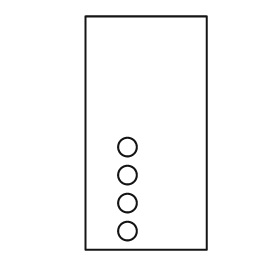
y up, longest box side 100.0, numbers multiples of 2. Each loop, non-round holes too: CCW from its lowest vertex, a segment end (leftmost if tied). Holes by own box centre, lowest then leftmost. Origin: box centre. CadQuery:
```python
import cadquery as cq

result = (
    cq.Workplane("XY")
    .moveTo(-26.0, -50.0)
    .lineTo(26.0, -50.0)
    .lineTo(26.0, 50.0)
    .lineTo(-26.0, 50.0)
    .close()
    .moveTo(-8.0, -42.0)
    .circle(4.0)
    .moveTo(-8.0, -30.0)
    .circle(4.0)
    .moveTo(-8.0, -18.0)
    .circle(4.0)
    .moveTo(-8.0, -6.0)
    .circle(4.0)
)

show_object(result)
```